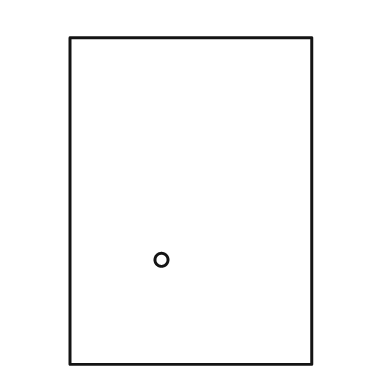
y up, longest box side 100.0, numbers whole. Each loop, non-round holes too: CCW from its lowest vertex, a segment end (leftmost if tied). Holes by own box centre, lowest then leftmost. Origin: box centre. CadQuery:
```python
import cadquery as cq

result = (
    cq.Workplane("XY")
    .moveTo(-37.0, -50.0)
    .lineTo(37.0, -50.0)
    .lineTo(37.0, 50.0)
    .lineTo(-37.0, 50.0)
    .close()
    .moveTo(-9.0, -18.0)
    .circle(2.0)
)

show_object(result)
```